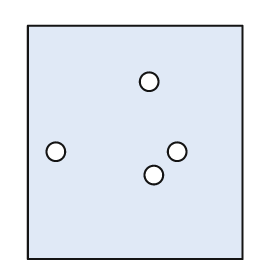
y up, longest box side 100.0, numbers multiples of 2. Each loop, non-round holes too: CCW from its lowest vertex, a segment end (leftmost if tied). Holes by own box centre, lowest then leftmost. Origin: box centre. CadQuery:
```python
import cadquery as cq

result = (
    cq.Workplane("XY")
    .moveTo(-46.0, -50.0)
    .lineTo(46.0, -50.0)
    .lineTo(46.0, 50.0)
    .lineTo(-46.0, 50.0)
    .close()
    .moveTo(8.0, -14.0)
    .circle(4.0)
    .moveTo(-34.0, -4.0)
    .circle(4.0)
    .moveTo(18.0, -4.0)
    .circle(4.0)
    .moveTo(6.0, 26.0)
    .circle(4.0)
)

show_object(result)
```